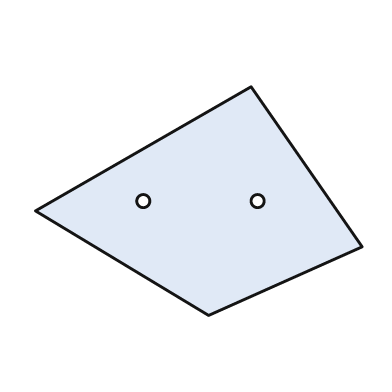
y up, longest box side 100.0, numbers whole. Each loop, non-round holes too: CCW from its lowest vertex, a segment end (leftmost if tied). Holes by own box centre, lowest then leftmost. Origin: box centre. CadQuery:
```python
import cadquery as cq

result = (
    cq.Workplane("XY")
    .moveTo(3.0, -35.0)
    .lineTo(50.0, -14.0)
    .lineTo(16.0, 35.0)
    .lineTo(-50.0, -3.0)
    .close()
    .moveTo(-17.0, 0.0)
    .circle(2.0)
    .moveTo(18.0, 0.0)
    .circle(2.0)
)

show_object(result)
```